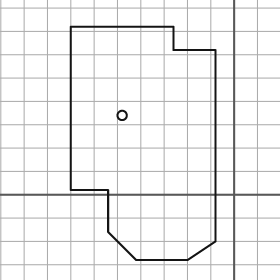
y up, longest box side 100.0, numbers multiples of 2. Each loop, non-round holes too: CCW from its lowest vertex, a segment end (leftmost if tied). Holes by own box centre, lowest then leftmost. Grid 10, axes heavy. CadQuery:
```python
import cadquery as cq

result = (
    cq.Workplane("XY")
    .moveTo(-42.0, -28.0)
    .lineTo(-20.0, -28.0)
    .lineTo(-8.0, -20.0)
    .lineTo(-8.0, 62.0)
    .lineTo(-26.0, 62.0)
    .lineTo(-26.0, 72.0)
    .lineTo(-70.0, 72.0)
    .lineTo(-70.0, 2.0)
    .lineTo(-54.0, 2.0)
    .lineTo(-54.0, -16.0)
    .close()
    .moveTo(-48.0, 34.0)
    .circle(2.0)
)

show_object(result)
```